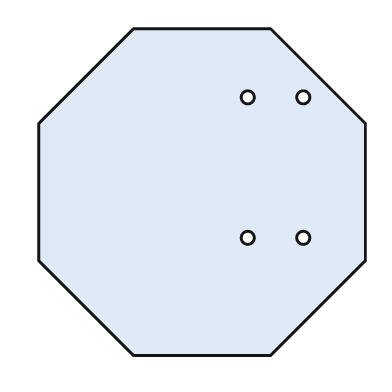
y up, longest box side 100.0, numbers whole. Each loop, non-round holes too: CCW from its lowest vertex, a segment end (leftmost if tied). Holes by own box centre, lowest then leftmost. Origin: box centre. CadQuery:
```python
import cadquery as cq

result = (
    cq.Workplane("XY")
    .moveTo(-21.0, -50.0)
    .lineTo(21.0, -50.0)
    .lineTo(50.0, -21.0)
    .lineTo(50.0, 21.0)
    .lineTo(21.0, 50.0)
    .lineTo(-21.0, 50.0)
    .lineTo(-50.0, 21.0)
    .lineTo(-50.0, -21.0)
    .close()
    .moveTo(14.0, -14.0)
    .circle(2.0)
    .moveTo(31.0, -14.0)
    .circle(2.0)
    .moveTo(14.0, 29.0)
    .circle(2.0)
    .moveTo(31.0, 29.0)
    .circle(2.0)
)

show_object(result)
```